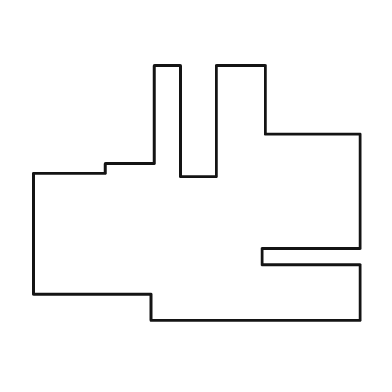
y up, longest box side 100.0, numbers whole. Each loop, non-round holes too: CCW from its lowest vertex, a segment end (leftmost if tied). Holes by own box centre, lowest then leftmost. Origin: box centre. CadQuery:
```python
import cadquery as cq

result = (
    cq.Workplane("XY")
    .moveTo(-14.0, -39.0)
    .lineTo(50.0, -39.0)
    .lineTo(50.0, -22.0)
    .lineTo(20.0, -22.0)
    .lineTo(20.0, -17.0)
    .lineTo(50.0, -17.0)
    .lineTo(50.0, 18.0)
    .lineTo(21.0, 18.0)
    .lineTo(21.0, 39.0)
    .lineTo(6.0, 39.0)
    .lineTo(6.0, 5.0)
    .lineTo(-5.0, 5.0)
    .lineTo(-5.0, 39.0)
    .lineTo(-13.0, 39.0)
    .lineTo(-13.0, 9.0)
    .lineTo(-28.0, 9.0)
    .lineTo(-28.0, 6.0)
    .lineTo(-50.0, 6.0)
    .lineTo(-50.0, -31.0)
    .lineTo(-14.0, -31.0)
    .close()
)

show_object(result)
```